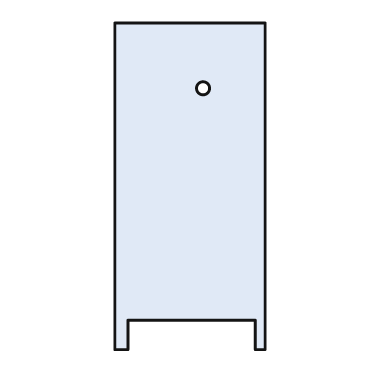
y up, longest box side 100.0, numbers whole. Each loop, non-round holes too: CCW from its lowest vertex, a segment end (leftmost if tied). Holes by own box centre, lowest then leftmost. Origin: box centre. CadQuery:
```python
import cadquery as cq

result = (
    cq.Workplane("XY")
    .moveTo(-23.0, -50.0)
    .lineTo(-19.0, -50.0)
    .lineTo(-19.0, -41.0)
    .lineTo(20.0, -41.0)
    .lineTo(20.0, -50.0)
    .lineTo(23.0, -50.0)
    .lineTo(23.0, 50.0)
    .lineTo(-23.0, 50.0)
    .close()
    .moveTo(4.0, 30.0)
    .circle(2.0)
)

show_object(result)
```